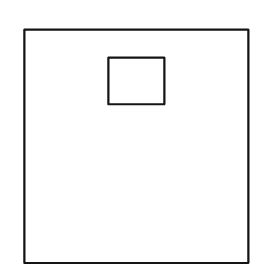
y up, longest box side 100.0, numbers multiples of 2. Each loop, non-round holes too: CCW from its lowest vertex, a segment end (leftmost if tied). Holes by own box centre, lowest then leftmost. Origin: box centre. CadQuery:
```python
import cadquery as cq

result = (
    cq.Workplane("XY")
    .moveTo(-48.0, -50.0)
    .lineTo(48.0, -50.0)
    .lineTo(48.0, 50.0)
    .lineTo(-48.0, 50.0)
    .close()
    .moveTo(-12.0, 18.0)
    .lineTo(12.0, 18.0)
    .lineTo(12.0, 38.0)
    .lineTo(-12.0, 38.0)
    .close()
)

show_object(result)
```